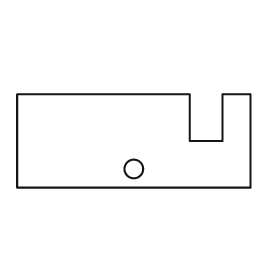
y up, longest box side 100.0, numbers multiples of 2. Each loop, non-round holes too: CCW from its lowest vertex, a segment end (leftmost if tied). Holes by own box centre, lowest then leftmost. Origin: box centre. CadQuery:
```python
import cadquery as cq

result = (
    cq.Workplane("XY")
    .moveTo(-50.0, -20.0)
    .lineTo(50.0, -20.0)
    .lineTo(50.0, 20.0)
    .lineTo(38.0, 20.0)
    .lineTo(38.0, 0.0)
    .lineTo(24.0, 0.0)
    .lineTo(24.0, 20.0)
    .lineTo(-50.0, 20.0)
    .close()
    .moveTo(0.0, -12.0)
    .circle(4.0)
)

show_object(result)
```